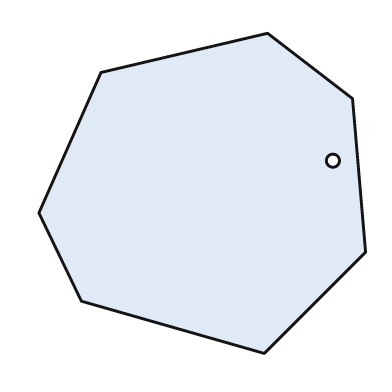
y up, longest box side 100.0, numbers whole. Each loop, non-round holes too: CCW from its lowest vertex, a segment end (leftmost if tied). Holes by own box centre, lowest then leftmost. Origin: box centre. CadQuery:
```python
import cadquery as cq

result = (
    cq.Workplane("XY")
    .moveTo(19.0, -49.0)
    .lineTo(50.0, -18.0)
    .lineTo(46.0, 29.0)
    .lineTo(20.0, 49.0)
    .lineTo(-31.0, 37.0)
    .lineTo(-50.0, -6.0)
    .lineTo(-37.0, -33.0)
    .close()
    .moveTo(40.0, 10.0)
    .circle(2.0)
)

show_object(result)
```